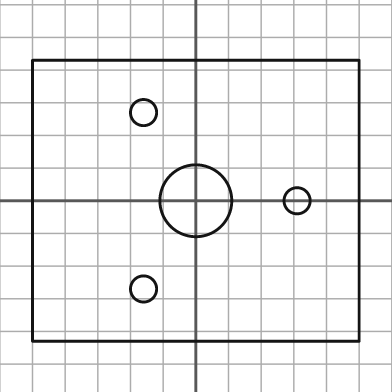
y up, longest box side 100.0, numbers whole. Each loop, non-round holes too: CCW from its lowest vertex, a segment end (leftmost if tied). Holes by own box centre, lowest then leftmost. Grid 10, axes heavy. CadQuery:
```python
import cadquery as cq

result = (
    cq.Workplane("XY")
    .moveTo(-50.0, -43.0)
    .lineTo(50.0, -43.0)
    .lineTo(50.0, 43.0)
    .lineTo(-50.0, 43.0)
    .close()
    .moveTo(-16.0, -27.0)
    .circle(4.0)
    .moveTo(0.0, 0.0)
    .circle(11.0)
    .moveTo(31.0, 0.0)
    .circle(4.0)
    .moveTo(-16.0, 27.0)
    .circle(4.0)
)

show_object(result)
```